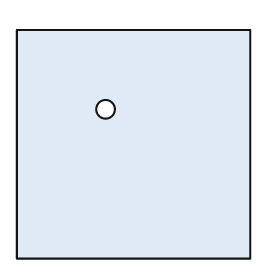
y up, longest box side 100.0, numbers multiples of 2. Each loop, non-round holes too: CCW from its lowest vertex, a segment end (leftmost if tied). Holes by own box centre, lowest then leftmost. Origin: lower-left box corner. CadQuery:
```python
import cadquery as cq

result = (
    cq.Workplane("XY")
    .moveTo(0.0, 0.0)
    .lineTo(100.0, 0.0)
    .lineTo(100.0, 98.0)
    .lineTo(0.0, 98.0)
    .close()
    .moveTo(38.0, 64.0)
    .circle(4.0)
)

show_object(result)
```